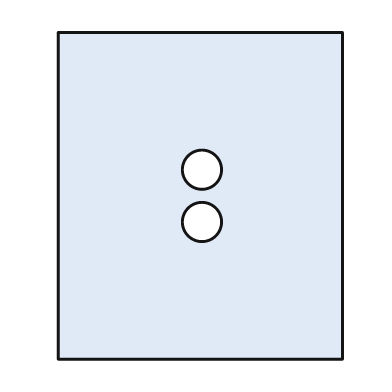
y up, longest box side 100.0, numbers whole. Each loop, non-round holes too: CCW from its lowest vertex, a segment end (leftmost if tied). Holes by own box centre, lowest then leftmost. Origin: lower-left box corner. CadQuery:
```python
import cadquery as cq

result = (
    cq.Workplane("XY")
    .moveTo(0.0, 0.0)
    .lineTo(87.0, 0.0)
    .lineTo(87.0, 100.0)
    .lineTo(0.0, 100.0)
    .close()
    .moveTo(44.0, 42.0)
    .circle(6.0)
    .moveTo(44.0, 58.0)
    .circle(6.0)
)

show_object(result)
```